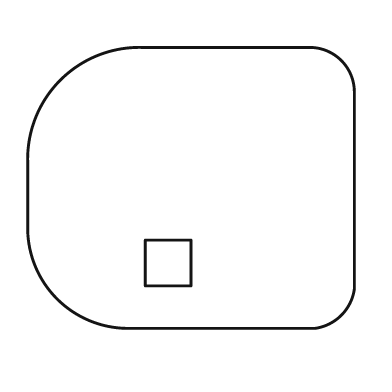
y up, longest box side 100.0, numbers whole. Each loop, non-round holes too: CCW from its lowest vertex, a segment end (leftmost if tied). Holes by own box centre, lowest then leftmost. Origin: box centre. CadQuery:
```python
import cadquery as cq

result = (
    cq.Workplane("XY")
    .moveTo(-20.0, -43.0)
    .lineTo(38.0, -43.0)
    .threePointArc((46.0, -39.0), (50.0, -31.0))
    .lineTo(50.0, 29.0)
    .threePointArc((46.0, 39.0), (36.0, 43.0))
    .lineTo(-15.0, 43.0)
    .threePointArc((-40.0, 33.0), (-50.0, 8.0))
    .lineTo(-50.0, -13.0)
    .threePointArc((-41.0, -34.0), (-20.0, -43.0))
    .close()
    .moveTo(-14.0, -30.0)
    .lineTo(0.0, -30.0)
    .lineTo(0.0, -16.0)
    .lineTo(-14.0, -16.0)
    .close()
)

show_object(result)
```